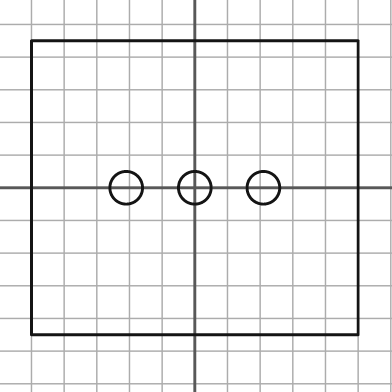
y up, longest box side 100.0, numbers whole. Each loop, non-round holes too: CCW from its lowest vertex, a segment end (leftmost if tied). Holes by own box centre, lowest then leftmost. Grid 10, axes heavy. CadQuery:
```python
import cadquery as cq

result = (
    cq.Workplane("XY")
    .moveTo(-50.0, -45.0)
    .lineTo(50.0, -45.0)
    .lineTo(50.0, 45.0)
    .lineTo(-50.0, 45.0)
    .close()
    .moveTo(-21.0, 0.0)
    .circle(5.0)
    .moveTo(0.0, 0.0)
    .circle(5.0)
    .moveTo(21.0, 0.0)
    .circle(5.0)
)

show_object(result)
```